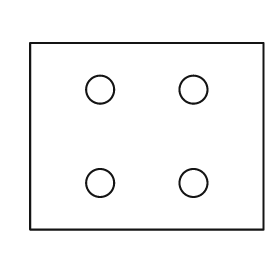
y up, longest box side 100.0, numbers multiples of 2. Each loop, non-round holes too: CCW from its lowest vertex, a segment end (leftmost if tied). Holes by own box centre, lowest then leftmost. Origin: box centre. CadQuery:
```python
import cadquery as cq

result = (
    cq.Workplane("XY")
    .moveTo(-50.0, -40.0)
    .lineTo(50.0, -40.0)
    .lineTo(50.0, 40.0)
    .lineTo(-50.0, 40.0)
    .close()
    .moveTo(-20.0, -20.0)
    .circle(6.0)
    .moveTo(20.0, -20.0)
    .circle(6.0)
    .moveTo(-20.0, 20.0)
    .circle(6.0)
    .moveTo(20.0, 20.0)
    .circle(6.0)
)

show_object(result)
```